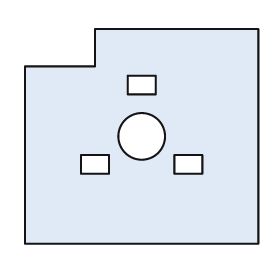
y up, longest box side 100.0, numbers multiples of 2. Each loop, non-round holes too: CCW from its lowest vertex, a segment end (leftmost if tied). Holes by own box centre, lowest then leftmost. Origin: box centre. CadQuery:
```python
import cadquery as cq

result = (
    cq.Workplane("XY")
    .moveTo(-50.0, -46.0)
    .lineTo(50.0, -46.0)
    .lineTo(50.0, 46.0)
    .lineTo(-20.0, 46.0)
    .lineTo(-20.0, 30.0)
    .lineTo(-50.0, 30.0)
    .close()
    .moveTo(-26.0, -16.0)
    .lineTo(-14.0, -16.0)
    .lineTo(-14.0, -8.0)
    .lineTo(-26.0, -8.0)
    .close()
    .moveTo(14.0, -16.0)
    .lineTo(26.0, -16.0)
    .lineTo(26.0, -8.0)
    .lineTo(14.0, -8.0)
    .close()
    .moveTo(0.0, 0.0)
    .circle(10.0)
    .moveTo(-6.0, 18.0)
    .lineTo(6.0, 18.0)
    .lineTo(6.0, 26.0)
    .lineTo(-6.0, 26.0)
    .close()
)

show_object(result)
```